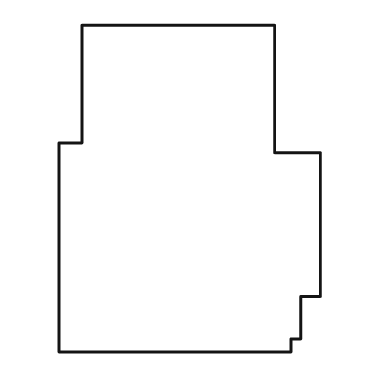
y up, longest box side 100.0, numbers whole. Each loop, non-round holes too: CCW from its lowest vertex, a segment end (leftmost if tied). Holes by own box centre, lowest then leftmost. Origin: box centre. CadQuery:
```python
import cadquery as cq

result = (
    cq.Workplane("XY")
    .moveTo(-40.0, -50.0)
    .lineTo(31.0, -50.0)
    .lineTo(31.0, -46.0)
    .lineTo(34.0, -46.0)
    .lineTo(34.0, -33.0)
    .lineTo(40.0, -33.0)
    .lineTo(40.0, 11.0)
    .lineTo(26.0, 11.0)
    .lineTo(26.0, 50.0)
    .lineTo(-33.0, 50.0)
    .lineTo(-33.0, 14.0)
    .lineTo(-40.0, 14.0)
    .close()
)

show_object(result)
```